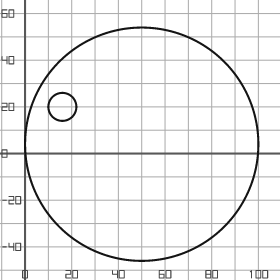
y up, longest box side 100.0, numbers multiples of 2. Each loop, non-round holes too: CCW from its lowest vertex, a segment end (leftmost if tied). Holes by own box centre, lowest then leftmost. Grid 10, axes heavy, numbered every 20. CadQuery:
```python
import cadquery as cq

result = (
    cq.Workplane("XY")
    .moveTo(50.0, 4.0)
    .circle(50.0)
    .moveTo(16.0, 20.0)
    .circle(6.0)
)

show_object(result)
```